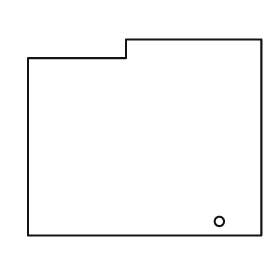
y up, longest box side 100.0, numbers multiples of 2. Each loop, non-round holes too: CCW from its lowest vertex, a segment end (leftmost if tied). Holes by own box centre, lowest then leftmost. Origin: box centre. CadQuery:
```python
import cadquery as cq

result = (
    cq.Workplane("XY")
    .moveTo(-50.0, -42.0)
    .lineTo(50.0, -42.0)
    .lineTo(50.0, 42.0)
    .lineTo(-8.0, 42.0)
    .lineTo(-8.0, 34.0)
    .lineTo(-50.0, 34.0)
    .close()
    .moveTo(32.0, -36.0)
    .circle(2.0)
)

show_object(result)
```